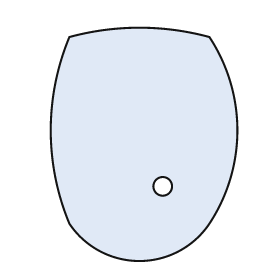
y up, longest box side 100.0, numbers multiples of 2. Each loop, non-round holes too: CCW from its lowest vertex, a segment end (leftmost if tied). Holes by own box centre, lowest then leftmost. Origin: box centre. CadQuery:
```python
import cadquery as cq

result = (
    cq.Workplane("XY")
    .moveTo(-32.0, -34.0)
    .threePointArc((-2.0, -50.0), (28.0, -34.0))
    .threePointArc((40.0, 6.0), (28.0, 46.0))
    .threePointArc((-2.0, 50.0), (-32.0, 46.0))
    .threePointArc((-40.0, 6.0), (-32.0, -34.0))
    .close()
    .moveTo(8.0, -18.0)
    .circle(4.0)
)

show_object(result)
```